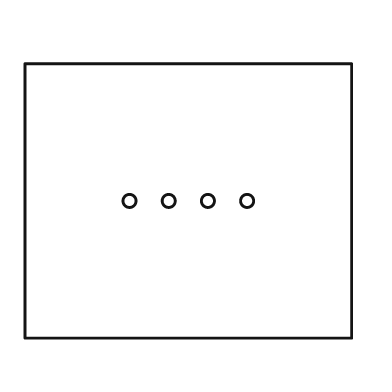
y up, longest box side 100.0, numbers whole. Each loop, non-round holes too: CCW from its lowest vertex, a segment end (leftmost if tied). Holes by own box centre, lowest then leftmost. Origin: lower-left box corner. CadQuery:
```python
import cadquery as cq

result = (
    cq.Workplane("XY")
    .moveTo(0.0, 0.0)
    .lineTo(100.0, 0.0)
    .lineTo(100.0, 84.0)
    .lineTo(0.0, 84.0)
    .close()
    .moveTo(32.0, 42.0)
    .circle(2.0)
    .moveTo(44.0, 42.0)
    .circle(2.0)
    .moveTo(56.0, 42.0)
    .circle(2.0)
    .moveTo(68.0, 42.0)
    .circle(2.0)
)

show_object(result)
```